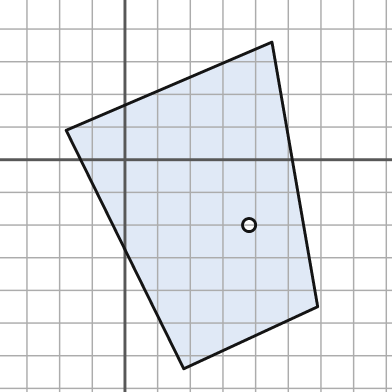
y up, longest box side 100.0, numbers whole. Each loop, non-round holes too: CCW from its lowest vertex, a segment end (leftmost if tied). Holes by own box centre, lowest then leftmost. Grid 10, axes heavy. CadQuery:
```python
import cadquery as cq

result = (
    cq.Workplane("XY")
    .moveTo(18.0, -64.0)
    .lineTo(59.0, -45.0)
    .lineTo(45.0, 36.0)
    .lineTo(-18.0, 9.0)
    .close()
    .moveTo(38.0, -20.0)
    .circle(2.0)
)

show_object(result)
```